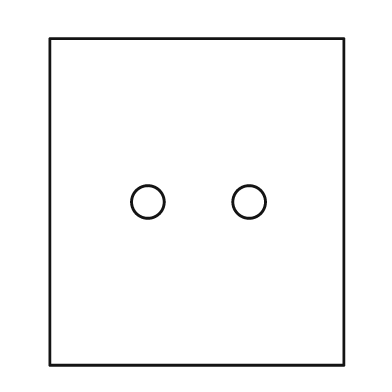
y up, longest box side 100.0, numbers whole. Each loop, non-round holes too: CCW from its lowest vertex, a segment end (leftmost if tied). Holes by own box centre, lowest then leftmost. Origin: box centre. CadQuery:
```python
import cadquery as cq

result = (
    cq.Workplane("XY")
    .moveTo(-45.0, -50.0)
    .lineTo(45.0, -50.0)
    .lineTo(45.0, 50.0)
    .lineTo(-45.0, 50.0)
    .close()
    .moveTo(-15.0, 0.0)
    .circle(5.0)
    .moveTo(16.0, 0.0)
    .circle(5.0)
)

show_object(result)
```